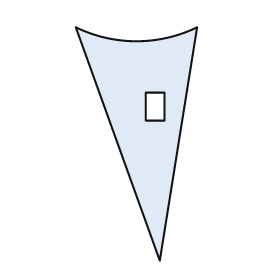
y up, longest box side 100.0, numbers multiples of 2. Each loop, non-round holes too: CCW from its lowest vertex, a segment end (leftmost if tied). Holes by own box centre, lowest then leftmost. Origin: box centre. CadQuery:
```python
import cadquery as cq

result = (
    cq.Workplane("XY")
    .moveTo(10.0, -50.0)
    .lineTo(26.0, 50.0)
    .threePointArc((0.0, 44.0), (-26.0, 50.0))
    .close()
    .moveTo(4.0, 10.0)
    .lineTo(12.0, 10.0)
    .lineTo(12.0, 22.0)
    .lineTo(4.0, 22.0)
    .close()
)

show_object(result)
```